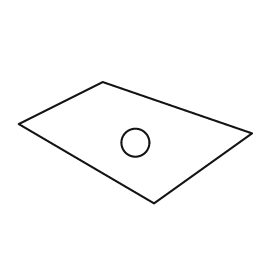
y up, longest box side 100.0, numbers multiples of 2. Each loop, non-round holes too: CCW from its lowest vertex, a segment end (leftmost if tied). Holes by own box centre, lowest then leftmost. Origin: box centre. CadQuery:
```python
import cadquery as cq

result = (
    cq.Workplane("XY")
    .moveTo(8.0, -26.0)
    .lineTo(50.0, 4.0)
    .lineTo(-14.0, 26.0)
    .lineTo(-50.0, 8.0)
    .close()
    .moveTo(0.0, 0.0)
    .circle(6.0)
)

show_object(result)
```